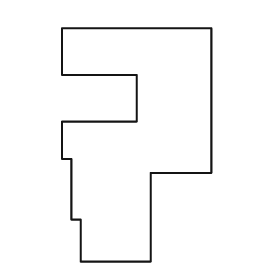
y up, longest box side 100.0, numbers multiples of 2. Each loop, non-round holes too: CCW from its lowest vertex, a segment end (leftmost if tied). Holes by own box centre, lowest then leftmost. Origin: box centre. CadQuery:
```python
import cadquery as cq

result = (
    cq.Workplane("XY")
    .moveTo(-24.0, -50.0)
    .lineTo(6.0, -50.0)
    .lineTo(6.0, -12.0)
    .lineTo(32.0, -12.0)
    .lineTo(32.0, 50.0)
    .lineTo(-32.0, 50.0)
    .lineTo(-32.0, 30.0)
    .lineTo(0.0, 30.0)
    .lineTo(0.0, 10.0)
    .lineTo(-32.0, 10.0)
    .lineTo(-32.0, -6.0)
    .lineTo(-28.0, -6.0)
    .lineTo(-28.0, -32.0)
    .lineTo(-24.0, -32.0)
    .close()
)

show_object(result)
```